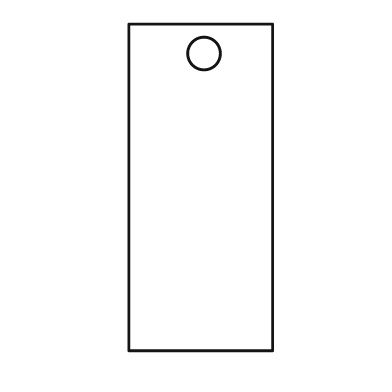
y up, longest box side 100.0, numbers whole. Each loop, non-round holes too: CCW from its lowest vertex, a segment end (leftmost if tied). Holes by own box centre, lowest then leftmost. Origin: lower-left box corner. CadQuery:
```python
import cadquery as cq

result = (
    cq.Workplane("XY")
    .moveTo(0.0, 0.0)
    .lineTo(44.0, 0.0)
    .lineTo(44.0, 100.0)
    .lineTo(0.0, 100.0)
    .close()
    .moveTo(23.0, 91.0)
    .circle(5.0)
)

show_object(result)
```